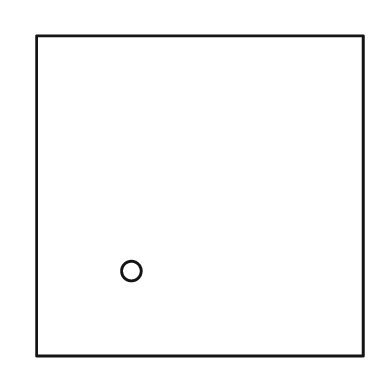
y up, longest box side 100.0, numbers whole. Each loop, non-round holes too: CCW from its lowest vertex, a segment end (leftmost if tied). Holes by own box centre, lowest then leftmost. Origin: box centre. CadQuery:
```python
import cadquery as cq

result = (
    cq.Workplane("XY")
    .moveTo(-50.0, -49.0)
    .lineTo(50.0, -49.0)
    .lineTo(50.0, 49.0)
    .lineTo(-50.0, 49.0)
    .close()
    .moveTo(-21.0, -23.0)
    .circle(3.0)
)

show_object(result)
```